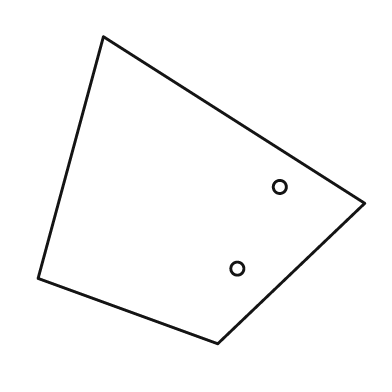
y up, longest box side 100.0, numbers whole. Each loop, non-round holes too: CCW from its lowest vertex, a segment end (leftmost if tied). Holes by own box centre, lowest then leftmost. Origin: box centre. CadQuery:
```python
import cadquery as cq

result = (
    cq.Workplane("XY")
    .moveTo(5.0, -47.0)
    .lineTo(50.0, -4.0)
    .lineTo(-30.0, 47.0)
    .lineTo(-50.0, -27.0)
    .close()
    .moveTo(11.0, -24.0)
    .circle(2.0)
    .moveTo(24.0, 1.0)
    .circle(2.0)
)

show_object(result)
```